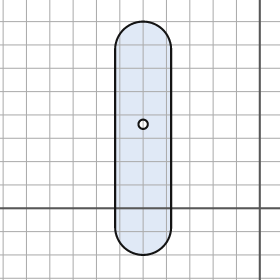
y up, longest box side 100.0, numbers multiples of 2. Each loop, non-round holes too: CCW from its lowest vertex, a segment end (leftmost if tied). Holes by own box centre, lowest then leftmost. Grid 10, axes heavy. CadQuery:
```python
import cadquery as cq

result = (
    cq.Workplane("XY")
    .moveTo(-62.0, -8.0)
    .threePointArc((-50.0, -20.0), (-38.0, -8.0))
    .lineTo(-38.0, 68.0)
    .threePointArc((-50.0, 80.0), (-62.0, 68.0))
    .close()
    .moveTo(-50.0, 36.0)
    .circle(2.0)
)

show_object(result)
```